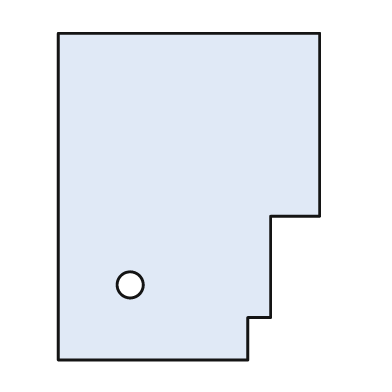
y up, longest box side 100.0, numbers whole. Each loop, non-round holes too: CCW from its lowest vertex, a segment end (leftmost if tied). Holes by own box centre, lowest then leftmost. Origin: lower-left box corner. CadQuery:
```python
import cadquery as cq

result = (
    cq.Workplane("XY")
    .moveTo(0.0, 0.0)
    .lineTo(58.0, 0.0)
    .lineTo(58.0, 13.0)
    .lineTo(65.0, 13.0)
    .lineTo(65.0, 44.0)
    .lineTo(80.0, 44.0)
    .lineTo(80.0, 100.0)
    .lineTo(0.0, 100.0)
    .close()
    .moveTo(22.0, 23.0)
    .circle(4.0)
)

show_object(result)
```